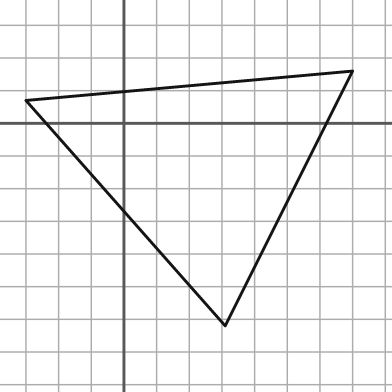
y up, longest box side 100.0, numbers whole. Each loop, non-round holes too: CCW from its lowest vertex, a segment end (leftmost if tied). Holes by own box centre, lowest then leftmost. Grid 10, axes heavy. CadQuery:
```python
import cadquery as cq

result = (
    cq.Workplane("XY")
    .moveTo(31.0, -62.0)
    .lineTo(70.0, 16.0)
    .lineTo(-30.0, 7.0)
    .close()
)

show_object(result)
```